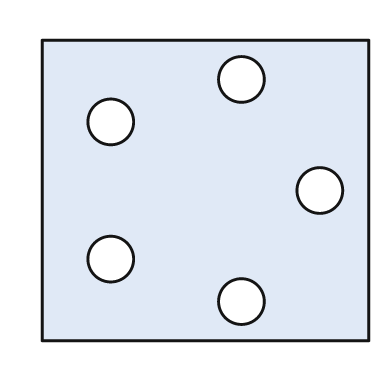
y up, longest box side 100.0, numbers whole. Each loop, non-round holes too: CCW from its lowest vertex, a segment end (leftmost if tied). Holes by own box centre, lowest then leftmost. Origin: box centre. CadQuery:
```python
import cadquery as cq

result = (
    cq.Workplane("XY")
    .moveTo(-50.0, -46.0)
    .lineTo(50.0, -46.0)
    .lineTo(50.0, 46.0)
    .lineTo(-50.0, 46.0)
    .close()
    .moveTo(11.0, -34.0)
    .circle(7.0)
    .moveTo(-29.0, -21.0)
    .circle(7.0)
    .moveTo(35.0, 0.0)
    .circle(7.0)
    .moveTo(-29.0, 21.0)
    .circle(7.0)
    .moveTo(11.0, 34.0)
    .circle(7.0)
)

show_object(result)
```